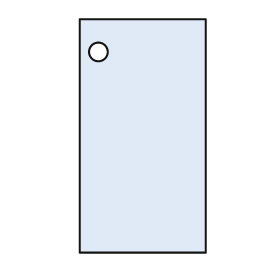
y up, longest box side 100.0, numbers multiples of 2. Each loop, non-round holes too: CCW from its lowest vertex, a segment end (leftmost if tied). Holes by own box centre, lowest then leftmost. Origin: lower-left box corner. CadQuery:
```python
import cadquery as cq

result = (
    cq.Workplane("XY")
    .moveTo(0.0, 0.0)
    .lineTo(54.0, 0.0)
    .lineTo(54.0, 100.0)
    .lineTo(0.0, 100.0)
    .close()
    .moveTo(8.0, 86.0)
    .circle(4.0)
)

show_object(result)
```